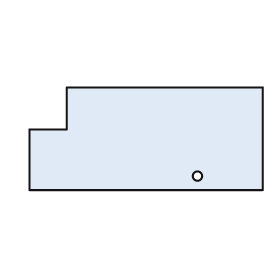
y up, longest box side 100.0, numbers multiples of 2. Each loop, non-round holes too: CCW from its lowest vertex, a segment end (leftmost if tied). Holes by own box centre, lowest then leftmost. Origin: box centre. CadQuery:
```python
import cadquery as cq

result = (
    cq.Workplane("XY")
    .moveTo(-50.0, -22.0)
    .lineTo(50.0, -22.0)
    .lineTo(50.0, 22.0)
    .lineTo(-34.0, 22.0)
    .lineTo(-34.0, 4.0)
    .lineTo(-50.0, 4.0)
    .close()
    .moveTo(22.0, -16.0)
    .circle(2.0)
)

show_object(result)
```